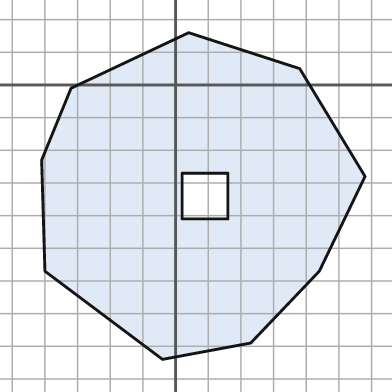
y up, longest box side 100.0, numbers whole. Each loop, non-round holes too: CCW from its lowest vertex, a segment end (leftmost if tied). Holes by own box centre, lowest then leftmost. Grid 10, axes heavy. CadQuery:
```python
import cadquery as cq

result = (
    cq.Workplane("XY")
    .moveTo(-4.0, -84.0)
    .lineTo(23.0, -79.0)
    .lineTo(44.0, -57.0)
    .lineTo(58.0, -28.0)
    .lineTo(38.0, 5.0)
    .lineTo(4.0, 16.0)
    .lineTo(-32.0, -1.0)
    .lineTo(-41.0, -23.0)
    .lineTo(-40.0, -57.0)
    .close()
    .moveTo(2.0, -41.0)
    .lineTo(16.0, -41.0)
    .lineTo(16.0, -27.0)
    .lineTo(2.0, -27.0)
    .close()
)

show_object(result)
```